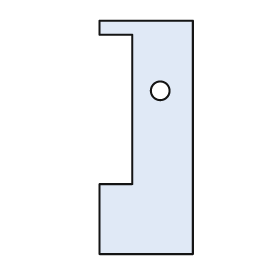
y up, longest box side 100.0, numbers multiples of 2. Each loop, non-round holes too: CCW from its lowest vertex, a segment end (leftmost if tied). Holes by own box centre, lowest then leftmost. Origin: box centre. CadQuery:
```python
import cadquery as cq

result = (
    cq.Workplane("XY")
    .moveTo(-20.0, -50.0)
    .lineTo(20.0, -50.0)
    .lineTo(20.0, 50.0)
    .lineTo(-20.0, 50.0)
    .lineTo(-20.0, 44.0)
    .lineTo(-6.0, 44.0)
    .lineTo(-6.0, -20.0)
    .lineTo(-20.0, -20.0)
    .close()
    .moveTo(6.0, 20.0)
    .circle(4.0)
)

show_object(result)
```